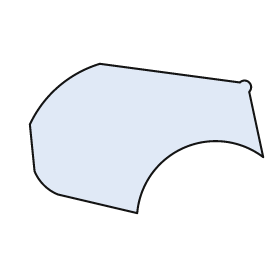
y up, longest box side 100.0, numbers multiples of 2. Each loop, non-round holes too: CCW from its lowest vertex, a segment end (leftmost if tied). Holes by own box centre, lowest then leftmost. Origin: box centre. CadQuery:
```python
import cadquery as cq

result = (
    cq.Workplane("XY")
    .moveTo(-4.0, -32.0)
    .threePointArc((16.0, -4.0), (50.0, -8.0))
    .lineTo(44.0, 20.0)
    .threePointArc((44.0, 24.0), (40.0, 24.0))
    .lineTo(-20.0, 32.0)
    .threePointArc((-38.0, 22.0), (-50.0, 6.0))
    .lineTo(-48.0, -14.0)
    .threePointArc((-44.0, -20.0), (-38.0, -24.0))
    .close()
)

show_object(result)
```